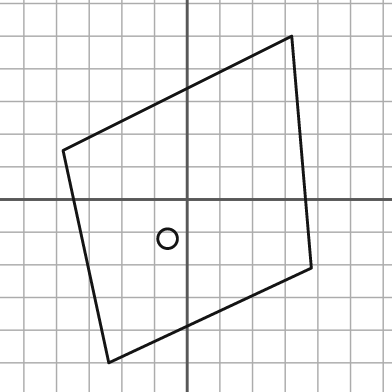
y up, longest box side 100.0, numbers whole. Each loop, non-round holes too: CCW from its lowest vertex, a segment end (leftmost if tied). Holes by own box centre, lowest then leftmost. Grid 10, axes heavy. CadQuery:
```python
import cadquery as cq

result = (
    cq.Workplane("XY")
    .moveTo(-24.0, -50.0)
    .lineTo(38.0, -21.0)
    .lineTo(32.0, 50.0)
    .lineTo(-38.0, 15.0)
    .close()
    .moveTo(-6.0, -12.0)
    .circle(3.0)
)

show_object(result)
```